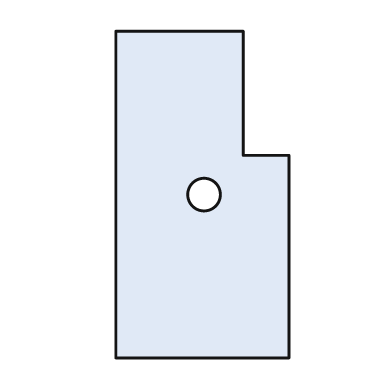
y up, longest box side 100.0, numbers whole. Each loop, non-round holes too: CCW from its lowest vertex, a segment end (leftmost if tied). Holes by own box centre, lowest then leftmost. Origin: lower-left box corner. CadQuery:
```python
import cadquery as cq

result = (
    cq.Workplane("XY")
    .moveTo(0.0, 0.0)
    .lineTo(53.0, 0.0)
    .lineTo(53.0, 62.0)
    .lineTo(39.0, 62.0)
    .lineTo(39.0, 100.0)
    .lineTo(0.0, 100.0)
    .close()
    .moveTo(27.0, 50.0)
    .circle(5.0)
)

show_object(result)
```